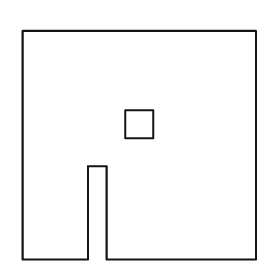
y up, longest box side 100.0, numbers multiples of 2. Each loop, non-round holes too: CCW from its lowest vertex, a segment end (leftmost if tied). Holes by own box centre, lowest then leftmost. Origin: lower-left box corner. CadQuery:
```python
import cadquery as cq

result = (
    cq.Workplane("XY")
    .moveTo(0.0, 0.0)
    .lineTo(28.0, 0.0)
    .lineTo(28.0, 40.0)
    .lineTo(36.0, 40.0)
    .lineTo(36.0, 0.0)
    .lineTo(100.0, 0.0)
    .lineTo(100.0, 98.0)
    .lineTo(0.0, 98.0)
    .close()
    .moveTo(44.0, 52.0)
    .lineTo(56.0, 52.0)
    .lineTo(56.0, 64.0)
    .lineTo(44.0, 64.0)
    .close()
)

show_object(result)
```